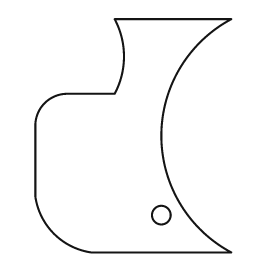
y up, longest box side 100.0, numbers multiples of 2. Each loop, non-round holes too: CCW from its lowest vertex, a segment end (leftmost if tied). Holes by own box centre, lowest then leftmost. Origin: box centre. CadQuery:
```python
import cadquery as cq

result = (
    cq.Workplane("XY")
    .moveTo(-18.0, -50.0)
    .lineTo(42.0, -50.0)
    .threePointArc((12.0, 0.0), (42.0, 50.0))
    .lineTo(-8.0, 50.0)
    .threePointArc((-4.0, 34.0), (-8.0, 18.0))
    .lineTo(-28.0, 18.0)
    .threePointArc((-38.0, 14.0), (-42.0, 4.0))
    .lineTo(-42.0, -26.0)
    .threePointArc((-34.0, -42.0), (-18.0, -50.0))
    .close()
    .moveTo(12.0, -34.0)
    .circle(4.0)
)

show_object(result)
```